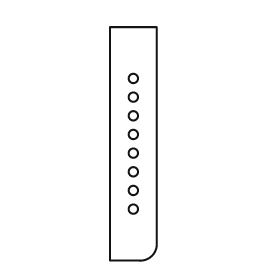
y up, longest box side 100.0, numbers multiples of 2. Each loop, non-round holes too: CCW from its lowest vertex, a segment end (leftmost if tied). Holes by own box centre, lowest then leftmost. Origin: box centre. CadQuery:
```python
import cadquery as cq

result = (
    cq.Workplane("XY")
    .moveTo(-10.0, -50.0)
    .lineTo(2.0, -50.0)
    .threePointArc((8.0, -48.0), (10.0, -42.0))
    .lineTo(10.0, 50.0)
    .lineTo(-10.0, 50.0)
    .close()
    .moveTo(0.0, -28.0)
    .circle(2.0)
    .moveTo(0.0, -20.0)
    .circle(2.0)
    .moveTo(0.0, -12.0)
    .circle(2.0)
    .moveTo(0.0, -4.0)
    .circle(2.0)
    .moveTo(0.0, 4.0)
    .circle(2.0)
    .moveTo(0.0, 12.0)
    .circle(2.0)
    .moveTo(0.0, 20.0)
    .circle(2.0)
    .moveTo(0.0, 28.0)
    .circle(2.0)
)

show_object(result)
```